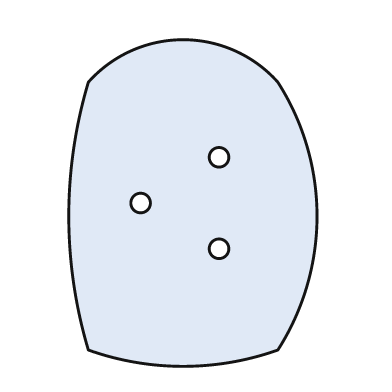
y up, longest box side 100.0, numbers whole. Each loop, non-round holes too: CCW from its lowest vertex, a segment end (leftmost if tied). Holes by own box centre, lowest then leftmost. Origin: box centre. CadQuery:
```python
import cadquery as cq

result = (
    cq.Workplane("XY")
    .moveTo(-32.0, -45.0)
    .threePointArc((-3.0, -50.0), (26.0, -45.0))
    .threePointArc((38.0, -4.0), (26.0, 37.0))
    .threePointArc((-3.0, 50.0), (-32.0, 37.0))
    .threePointArc((-38.0, -4.0), (-32.0, -45.0))
    .close()
    .moveTo(8.0, -14.0)
    .circle(3.0)
    .moveTo(-16.0, 0.0)
    .circle(3.0)
    .moveTo(8.0, 14.0)
    .circle(3.0)
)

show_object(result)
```